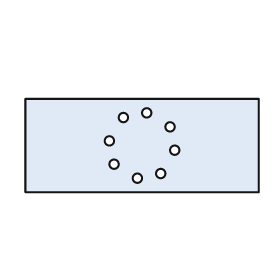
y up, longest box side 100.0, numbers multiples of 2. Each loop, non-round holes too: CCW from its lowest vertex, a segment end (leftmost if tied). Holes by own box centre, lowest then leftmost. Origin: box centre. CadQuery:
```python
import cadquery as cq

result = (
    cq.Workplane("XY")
    .moveTo(-50.0, -20.0)
    .lineTo(50.0, -20.0)
    .lineTo(50.0, 20.0)
    .lineTo(-50.0, 20.0)
    .close()
    .moveTo(-2.0, -14.0)
    .circle(2.0)
    .moveTo(8.0, -12.0)
    .circle(2.0)
    .moveTo(-12.0, -8.0)
    .circle(2.0)
    .moveTo(14.0, -2.0)
    .circle(2.0)
    .moveTo(-14.0, 2.0)
    .circle(2.0)
    .moveTo(12.0, 8.0)
    .circle(2.0)
    .moveTo(-8.0, 12.0)
    .circle(2.0)
    .moveTo(2.0, 14.0)
    .circle(2.0)
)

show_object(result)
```